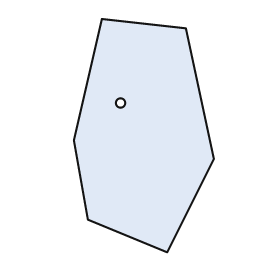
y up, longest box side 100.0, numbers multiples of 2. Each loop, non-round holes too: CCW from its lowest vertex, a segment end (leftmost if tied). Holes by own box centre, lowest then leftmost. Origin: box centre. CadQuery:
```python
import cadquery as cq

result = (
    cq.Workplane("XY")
    .moveTo(10.0, -50.0)
    .lineTo(30.0, -10.0)
    .lineTo(18.0, 46.0)
    .lineTo(-18.0, 50.0)
    .lineTo(-30.0, -2.0)
    .lineTo(-24.0, -36.0)
    .close()
    .moveTo(-10.0, 14.0)
    .circle(2.0)
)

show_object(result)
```